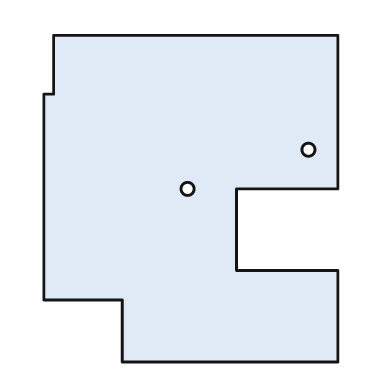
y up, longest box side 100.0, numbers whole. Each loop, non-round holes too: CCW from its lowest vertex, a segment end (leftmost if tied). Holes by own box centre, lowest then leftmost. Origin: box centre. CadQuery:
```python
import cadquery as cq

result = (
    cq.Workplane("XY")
    .moveTo(-21.0, -50.0)
    .lineTo(45.0, -50.0)
    .lineTo(45.0, -22.0)
    .lineTo(14.0, -22.0)
    .lineTo(14.0, 3.0)
    .lineTo(45.0, 3.0)
    .lineTo(45.0, 50.0)
    .lineTo(-42.0, 50.0)
    .lineTo(-42.0, 32.0)
    .lineTo(-45.0, 32.0)
    .lineTo(-45.0, -31.0)
    .lineTo(-21.0, -31.0)
    .close()
    .moveTo(-1.0, 3.0)
    .circle(2.0)
    .moveTo(36.0, 15.0)
    .circle(2.0)
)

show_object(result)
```